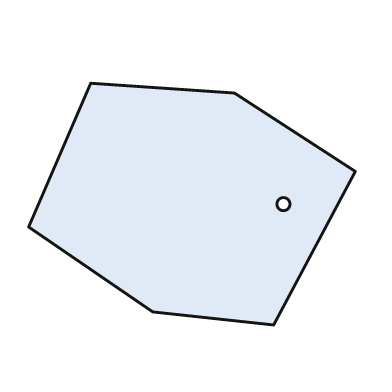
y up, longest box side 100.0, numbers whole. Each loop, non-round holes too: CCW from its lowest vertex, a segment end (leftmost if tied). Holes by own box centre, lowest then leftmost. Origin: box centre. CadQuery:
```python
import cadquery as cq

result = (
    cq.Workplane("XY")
    .moveTo(25.0, -37.0)
    .lineTo(50.0, 10.0)
    .lineTo(13.0, 34.0)
    .lineTo(-31.0, 37.0)
    .lineTo(-50.0, -7.0)
    .lineTo(-12.0, -33.0)
    .close()
    .moveTo(28.0, 0.0)
    .circle(2.0)
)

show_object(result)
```